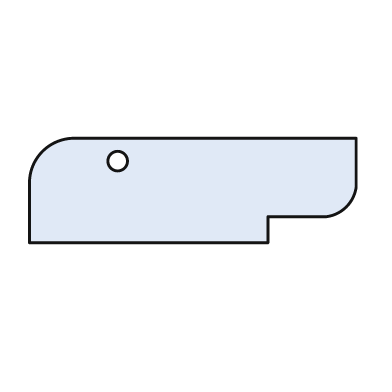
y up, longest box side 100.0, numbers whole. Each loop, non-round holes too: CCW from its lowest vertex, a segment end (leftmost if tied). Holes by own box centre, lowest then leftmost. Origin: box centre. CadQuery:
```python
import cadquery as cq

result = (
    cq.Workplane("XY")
    .moveTo(-50.0, -16.0)
    .lineTo(23.0, -16.0)
    .lineTo(23.0, -8.0)
    .lineTo(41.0, -8.0)
    .threePointArc((47.0, -5.0), (50.0, 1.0))
    .lineTo(50.0, 16.0)
    .lineTo(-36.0, 16.0)
    .threePointArc((-46.0, 12.0), (-50.0, 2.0))
    .close()
    .moveTo(-23.0, 9.0)
    .circle(3.0)
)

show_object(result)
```